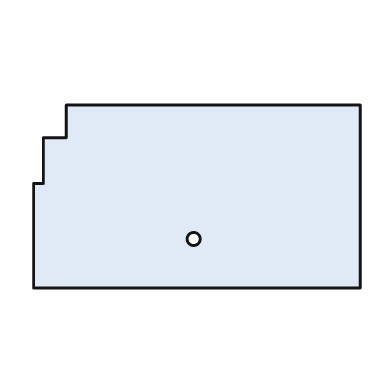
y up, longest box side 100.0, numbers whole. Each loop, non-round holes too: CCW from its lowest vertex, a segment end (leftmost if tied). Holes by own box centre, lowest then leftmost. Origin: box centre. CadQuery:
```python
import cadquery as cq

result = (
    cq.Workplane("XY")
    .moveTo(-50.0, -28.0)
    .lineTo(50.0, -28.0)
    .lineTo(50.0, 28.0)
    .lineTo(-40.0, 28.0)
    .lineTo(-40.0, 18.0)
    .lineTo(-47.0, 18.0)
    .lineTo(-47.0, 4.0)
    .lineTo(-50.0, 4.0)
    .close()
    .moveTo(-1.0, -13.0)
    .circle(2.0)
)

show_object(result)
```